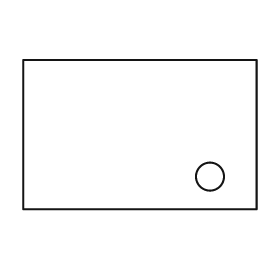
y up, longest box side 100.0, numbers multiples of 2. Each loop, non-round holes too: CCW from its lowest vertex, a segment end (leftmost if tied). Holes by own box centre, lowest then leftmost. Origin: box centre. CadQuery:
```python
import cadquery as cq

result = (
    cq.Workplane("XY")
    .moveTo(-50.0, -32.0)
    .lineTo(50.0, -32.0)
    .lineTo(50.0, 32.0)
    .lineTo(-50.0, 32.0)
    .close()
    .moveTo(30.0, -18.0)
    .circle(6.0)
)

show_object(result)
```